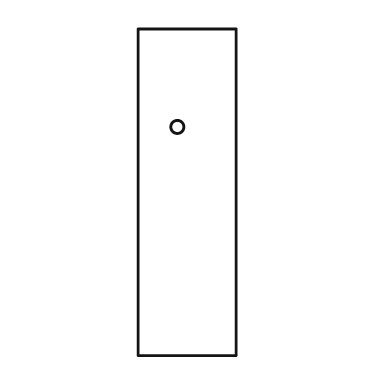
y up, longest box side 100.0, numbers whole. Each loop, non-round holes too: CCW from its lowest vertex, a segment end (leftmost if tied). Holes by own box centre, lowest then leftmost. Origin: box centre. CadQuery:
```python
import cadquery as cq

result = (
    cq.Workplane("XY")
    .moveTo(-15.0, -50.0)
    .lineTo(15.0, -50.0)
    .lineTo(15.0, 50.0)
    .lineTo(-15.0, 50.0)
    .close()
    .moveTo(-3.0, 20.0)
    .circle(2.0)
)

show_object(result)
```